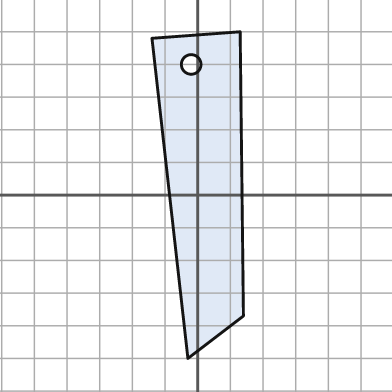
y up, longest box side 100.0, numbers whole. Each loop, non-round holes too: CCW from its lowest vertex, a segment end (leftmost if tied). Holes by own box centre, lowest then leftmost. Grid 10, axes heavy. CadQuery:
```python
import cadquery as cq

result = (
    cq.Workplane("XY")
    .moveTo(-3.0, -50.0)
    .lineTo(14.0, -37.0)
    .lineTo(13.0, 50.0)
    .lineTo(-14.0, 48.0)
    .close()
    .moveTo(-2.0, 40.0)
    .circle(3.0)
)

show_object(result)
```